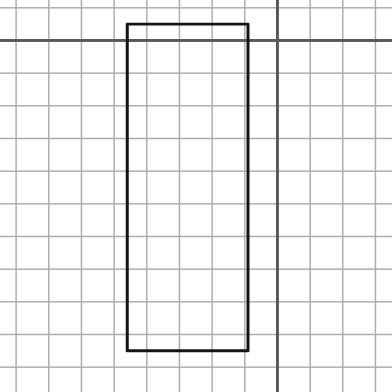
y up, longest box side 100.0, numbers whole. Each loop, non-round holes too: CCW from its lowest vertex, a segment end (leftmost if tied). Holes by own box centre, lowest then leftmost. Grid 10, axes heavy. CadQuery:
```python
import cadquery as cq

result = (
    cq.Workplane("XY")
    .moveTo(-46.0, -95.0)
    .lineTo(-9.0, -95.0)
    .lineTo(-9.0, 5.0)
    .lineTo(-46.0, 5.0)
    .close()
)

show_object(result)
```